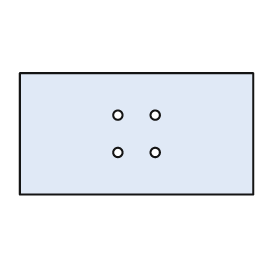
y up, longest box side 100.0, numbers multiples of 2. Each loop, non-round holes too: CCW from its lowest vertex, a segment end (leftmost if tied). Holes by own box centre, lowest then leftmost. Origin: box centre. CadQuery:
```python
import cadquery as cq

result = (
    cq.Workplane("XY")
    .moveTo(-50.0, -26.0)
    .lineTo(50.0, -26.0)
    .lineTo(50.0, 26.0)
    .lineTo(-50.0, 26.0)
    .close()
    .moveTo(-8.0, -8.0)
    .circle(2.0)
    .moveTo(8.0, -8.0)
    .circle(2.0)
    .moveTo(-8.0, 8.0)
    .circle(2.0)
    .moveTo(8.0, 8.0)
    .circle(2.0)
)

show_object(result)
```